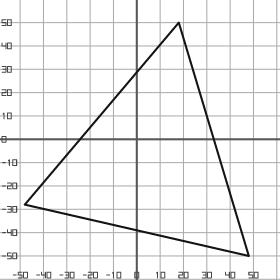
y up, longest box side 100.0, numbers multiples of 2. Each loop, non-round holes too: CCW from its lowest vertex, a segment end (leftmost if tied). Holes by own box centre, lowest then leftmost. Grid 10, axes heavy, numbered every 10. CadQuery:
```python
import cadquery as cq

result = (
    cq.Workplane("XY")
    .moveTo(48.0, -50.0)
    .lineTo(18.0, 50.0)
    .lineTo(-48.0, -28.0)
    .close()
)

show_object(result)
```